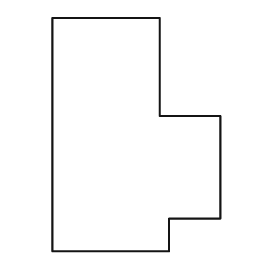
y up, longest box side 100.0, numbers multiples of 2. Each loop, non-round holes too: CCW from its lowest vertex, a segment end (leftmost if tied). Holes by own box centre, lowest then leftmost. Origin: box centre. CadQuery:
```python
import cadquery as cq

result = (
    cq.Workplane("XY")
    .moveTo(-36.0, -50.0)
    .lineTo(14.0, -50.0)
    .lineTo(14.0, -36.0)
    .lineTo(36.0, -36.0)
    .lineTo(36.0, 8.0)
    .lineTo(10.0, 8.0)
    .lineTo(10.0, 50.0)
    .lineTo(-36.0, 50.0)
    .close()
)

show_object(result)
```